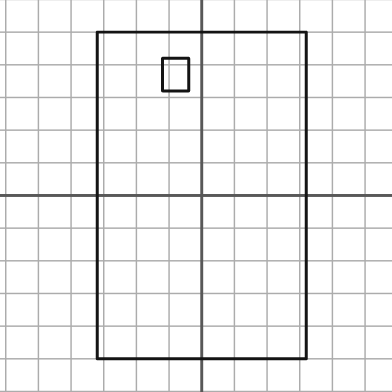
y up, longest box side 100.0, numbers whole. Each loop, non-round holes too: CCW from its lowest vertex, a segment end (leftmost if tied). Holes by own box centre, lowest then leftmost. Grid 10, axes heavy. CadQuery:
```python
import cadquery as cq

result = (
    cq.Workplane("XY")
    .moveTo(-32.0, -50.0)
    .lineTo(32.0, -50.0)
    .lineTo(32.0, 50.0)
    .lineTo(-32.0, 50.0)
    .close()
    .moveTo(-12.0, 32.0)
    .lineTo(-4.0, 32.0)
    .lineTo(-4.0, 42.0)
    .lineTo(-12.0, 42.0)
    .close()
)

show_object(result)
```